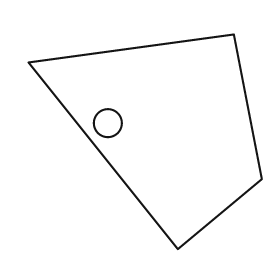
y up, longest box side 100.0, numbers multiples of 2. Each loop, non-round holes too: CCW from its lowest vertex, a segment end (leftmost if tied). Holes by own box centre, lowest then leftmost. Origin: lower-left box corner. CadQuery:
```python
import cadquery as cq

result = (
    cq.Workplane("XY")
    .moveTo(64.0, 0.0)
    .lineTo(100.0, 30.0)
    .lineTo(88.0, 92.0)
    .lineTo(0.0, 80.0)
    .close()
    .moveTo(34.0, 54.0)
    .circle(6.0)
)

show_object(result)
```